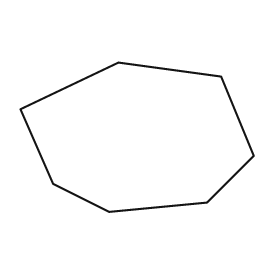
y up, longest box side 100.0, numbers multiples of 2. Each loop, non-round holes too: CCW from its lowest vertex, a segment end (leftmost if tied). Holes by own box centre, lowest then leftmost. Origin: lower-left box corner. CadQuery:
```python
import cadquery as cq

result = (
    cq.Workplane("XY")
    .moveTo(38.0, 0.0)
    .lineTo(80.0, 4.0)
    .lineTo(100.0, 24.0)
    .lineTo(86.0, 58.0)
    .lineTo(42.0, 64.0)
    .lineTo(0.0, 44.0)
    .lineTo(14.0, 12.0)
    .close()
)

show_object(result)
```